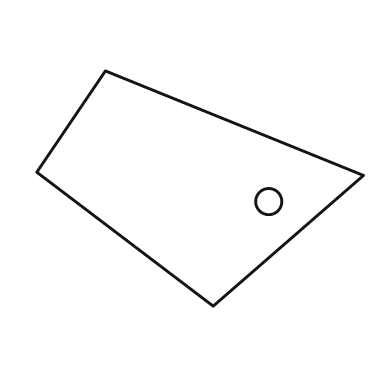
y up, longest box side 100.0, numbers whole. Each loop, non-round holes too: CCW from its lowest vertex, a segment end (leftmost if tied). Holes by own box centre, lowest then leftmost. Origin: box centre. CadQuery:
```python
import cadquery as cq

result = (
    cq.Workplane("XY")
    .moveTo(4.0, -36.0)
    .lineTo(50.0, 4.0)
    .lineTo(-29.0, 36.0)
    .lineTo(-50.0, 5.0)
    .close()
    .moveTo(21.0, -4.0)
    .circle(4.0)
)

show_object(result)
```